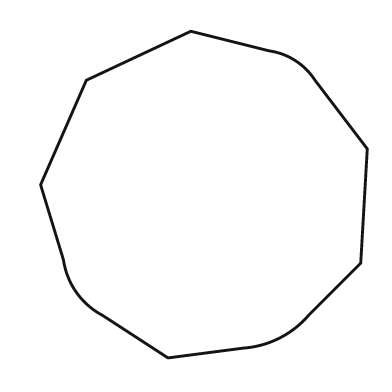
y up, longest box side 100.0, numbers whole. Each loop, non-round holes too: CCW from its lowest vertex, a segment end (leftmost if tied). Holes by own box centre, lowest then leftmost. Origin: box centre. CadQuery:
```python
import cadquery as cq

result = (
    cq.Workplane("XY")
    .moveTo(-11.0, -50.0)
    .lineTo(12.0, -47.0)
    .threePointArc((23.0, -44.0), (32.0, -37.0))
    .lineTo(48.0, -21.0)
    .lineTo(50.0, 14.0)
    .lineTo(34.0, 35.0)
    .threePointArc((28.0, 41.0), (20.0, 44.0))
    .lineTo(-4.0, 50.0)
    .lineTo(-36.0, 35.0)
    .lineTo(-50.0, 3.0)
    .lineTo(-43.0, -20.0)
    .threePointArc((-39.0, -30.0), (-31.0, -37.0))
    .close()
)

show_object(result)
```